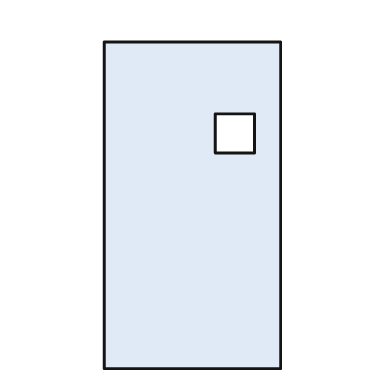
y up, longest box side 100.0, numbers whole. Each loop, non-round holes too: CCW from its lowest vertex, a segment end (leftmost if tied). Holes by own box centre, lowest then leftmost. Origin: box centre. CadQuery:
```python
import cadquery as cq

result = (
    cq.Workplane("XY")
    .moveTo(-27.0, -50.0)
    .lineTo(27.0, -50.0)
    .lineTo(27.0, 50.0)
    .lineTo(-27.0, 50.0)
    .close()
    .moveTo(7.0, 16.0)
    .lineTo(19.0, 16.0)
    .lineTo(19.0, 28.0)
    .lineTo(7.0, 28.0)
    .close()
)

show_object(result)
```